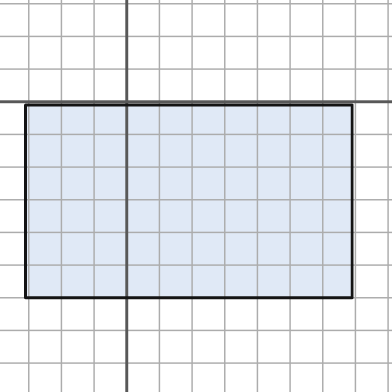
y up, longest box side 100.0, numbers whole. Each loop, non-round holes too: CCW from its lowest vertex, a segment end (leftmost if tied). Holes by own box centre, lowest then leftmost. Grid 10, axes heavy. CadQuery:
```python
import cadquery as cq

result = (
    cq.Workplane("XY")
    .moveTo(-31.0, -60.0)
    .lineTo(69.0, -60.0)
    .lineTo(69.0, -1.0)
    .lineTo(-31.0, -1.0)
    .close()
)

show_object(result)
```